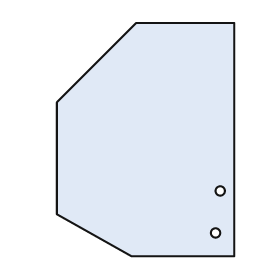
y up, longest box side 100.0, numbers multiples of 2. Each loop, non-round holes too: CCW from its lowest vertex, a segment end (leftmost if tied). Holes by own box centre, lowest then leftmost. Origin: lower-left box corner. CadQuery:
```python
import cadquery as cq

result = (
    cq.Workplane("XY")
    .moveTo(32.0, 0.0)
    .lineTo(76.0, 0.0)
    .lineTo(76.0, 100.0)
    .lineTo(34.0, 100.0)
    .lineTo(0.0, 66.0)
    .lineTo(0.0, 18.0)
    .close()
    .moveTo(68.0, 10.0)
    .circle(2.0)
    .moveTo(70.0, 28.0)
    .circle(2.0)
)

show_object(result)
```